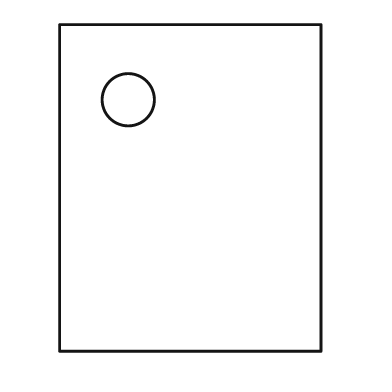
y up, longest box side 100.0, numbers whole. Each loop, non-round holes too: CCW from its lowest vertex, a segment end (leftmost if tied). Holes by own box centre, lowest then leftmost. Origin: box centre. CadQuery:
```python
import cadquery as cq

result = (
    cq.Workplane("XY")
    .moveTo(-40.0, -50.0)
    .lineTo(40.0, -50.0)
    .lineTo(40.0, 50.0)
    .lineTo(-40.0, 50.0)
    .close()
    .moveTo(-19.0, 27.0)
    .circle(8.0)
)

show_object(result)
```